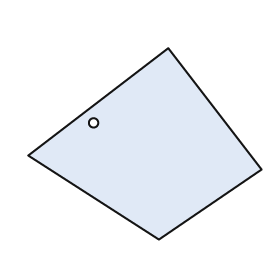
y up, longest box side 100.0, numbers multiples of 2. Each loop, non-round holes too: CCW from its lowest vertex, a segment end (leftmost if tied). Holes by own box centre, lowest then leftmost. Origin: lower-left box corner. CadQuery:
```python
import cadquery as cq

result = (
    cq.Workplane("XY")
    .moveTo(56.0, 0.0)
    .lineTo(100.0, 30.0)
    .lineTo(60.0, 82.0)
    .lineTo(0.0, 36.0)
    .close()
    .moveTo(28.0, 50.0)
    .circle(2.0)
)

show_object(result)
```